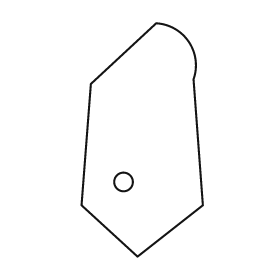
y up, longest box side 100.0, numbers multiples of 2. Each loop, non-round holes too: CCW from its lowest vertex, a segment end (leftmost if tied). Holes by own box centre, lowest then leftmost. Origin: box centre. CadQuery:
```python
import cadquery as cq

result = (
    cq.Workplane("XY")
    .moveTo(-2.0, -50.0)
    .lineTo(26.0, -28.0)
    .lineTo(22.0, 26.0)
    .threePointArc((20.0, 42.0), (6.0, 50.0))
    .lineTo(-22.0, 24.0)
    .lineTo(-26.0, -28.0)
    .close()
    .moveTo(-8.0, -18.0)
    .circle(4.0)
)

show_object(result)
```